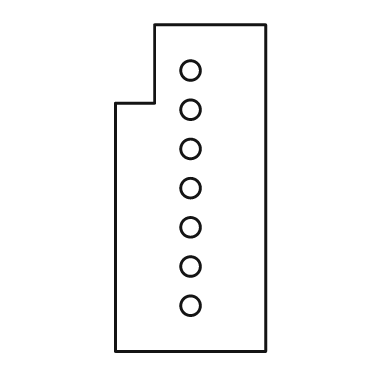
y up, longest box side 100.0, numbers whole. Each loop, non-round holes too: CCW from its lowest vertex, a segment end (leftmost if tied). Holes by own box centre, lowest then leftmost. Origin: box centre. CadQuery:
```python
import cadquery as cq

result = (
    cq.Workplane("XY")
    .moveTo(-23.0, -50.0)
    .lineTo(23.0, -50.0)
    .lineTo(23.0, 50.0)
    .lineTo(-11.0, 50.0)
    .lineTo(-11.0, 26.0)
    .lineTo(-23.0, 26.0)
    .close()
    .moveTo(0.0, -36.0)
    .circle(3.0)
    .moveTo(0.0, -24.0)
    .circle(3.0)
    .moveTo(0.0, -12.0)
    .circle(3.0)
    .moveTo(0.0, 0.0)
    .circle(3.0)
    .moveTo(0.0, 12.0)
    .circle(3.0)
    .moveTo(0.0, 24.0)
    .circle(3.0)
    .moveTo(0.0, 36.0)
    .circle(3.0)
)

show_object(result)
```